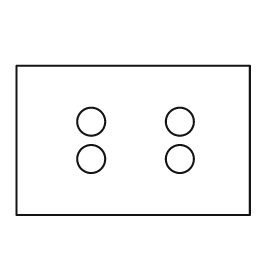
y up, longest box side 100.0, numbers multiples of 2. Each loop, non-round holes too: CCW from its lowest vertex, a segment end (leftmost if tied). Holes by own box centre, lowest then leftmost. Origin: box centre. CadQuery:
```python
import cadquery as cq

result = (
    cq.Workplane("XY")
    .moveTo(-50.0, -32.0)
    .lineTo(50.0, -32.0)
    .lineTo(50.0, 32.0)
    .lineTo(-50.0, 32.0)
    .close()
    .moveTo(-18.0, -8.0)
    .circle(6.0)
    .moveTo(20.0, -8.0)
    .circle(6.0)
    .moveTo(-18.0, 8.0)
    .circle(6.0)
    .moveTo(20.0, 8.0)
    .circle(6.0)
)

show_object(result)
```